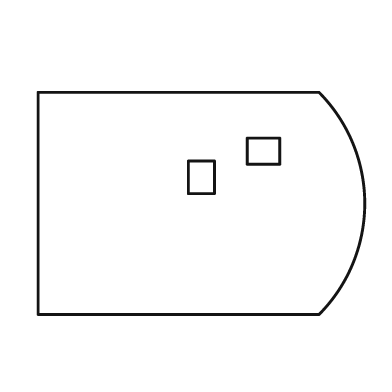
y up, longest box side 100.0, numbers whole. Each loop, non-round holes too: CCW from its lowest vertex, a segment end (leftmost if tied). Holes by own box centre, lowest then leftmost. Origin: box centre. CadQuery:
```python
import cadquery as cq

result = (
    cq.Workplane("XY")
    .moveTo(-50.0, -34.0)
    .lineTo(36.0, -34.0)
    .threePointArc((50.0, 0.0), (36.0, 34.0))
    .lineTo(-50.0, 34.0)
    .close()
    .moveTo(-4.0, 3.0)
    .lineTo(4.0, 3.0)
    .lineTo(4.0, 13.0)
    .lineTo(-4.0, 13.0)
    .close()
    .moveTo(14.0, 12.0)
    .lineTo(24.0, 12.0)
    .lineTo(24.0, 20.0)
    .lineTo(14.0, 20.0)
    .close()
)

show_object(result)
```